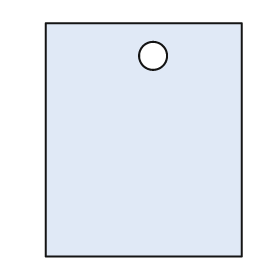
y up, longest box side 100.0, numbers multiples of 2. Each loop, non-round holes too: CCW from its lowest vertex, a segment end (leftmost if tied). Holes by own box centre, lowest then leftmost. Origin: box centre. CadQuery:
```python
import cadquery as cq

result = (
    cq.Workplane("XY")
    .moveTo(-42.0, -50.0)
    .lineTo(42.0, -50.0)
    .lineTo(42.0, 50.0)
    .lineTo(-42.0, 50.0)
    .close()
    .moveTo(4.0, 36.0)
    .circle(6.0)
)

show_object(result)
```